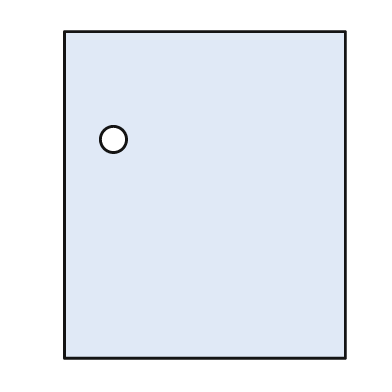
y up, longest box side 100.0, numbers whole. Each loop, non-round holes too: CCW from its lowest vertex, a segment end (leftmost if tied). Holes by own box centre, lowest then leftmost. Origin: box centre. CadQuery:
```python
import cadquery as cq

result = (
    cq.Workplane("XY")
    .moveTo(-43.0, -50.0)
    .lineTo(43.0, -50.0)
    .lineTo(43.0, 50.0)
    .lineTo(-43.0, 50.0)
    .close()
    .moveTo(-28.0, 17.0)
    .circle(4.0)
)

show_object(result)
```